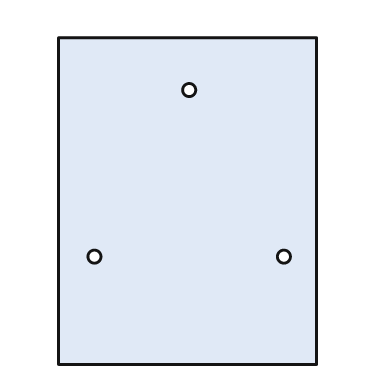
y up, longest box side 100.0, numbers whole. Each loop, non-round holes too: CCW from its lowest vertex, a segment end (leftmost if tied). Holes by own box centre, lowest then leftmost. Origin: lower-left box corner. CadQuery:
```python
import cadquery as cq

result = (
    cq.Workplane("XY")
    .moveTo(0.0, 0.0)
    .lineTo(79.0, 0.0)
    .lineTo(79.0, 100.0)
    .lineTo(0.0, 100.0)
    .close()
    .moveTo(11.0, 33.0)
    .circle(2.0)
    .moveTo(69.0, 33.0)
    .circle(2.0)
    .moveTo(40.0, 84.0)
    .circle(2.0)
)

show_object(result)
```